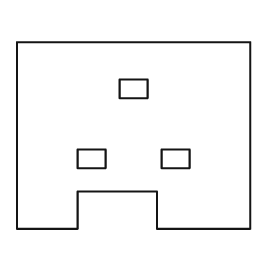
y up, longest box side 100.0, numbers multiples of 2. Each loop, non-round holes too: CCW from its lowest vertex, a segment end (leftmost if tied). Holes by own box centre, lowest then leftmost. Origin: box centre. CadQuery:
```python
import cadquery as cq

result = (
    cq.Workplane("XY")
    .moveTo(-50.0, -40.0)
    .lineTo(-24.0, -40.0)
    .lineTo(-24.0, -24.0)
    .lineTo(10.0, -24.0)
    .lineTo(10.0, -40.0)
    .lineTo(50.0, -40.0)
    .lineTo(50.0, 40.0)
    .lineTo(-50.0, 40.0)
    .close()
    .moveTo(-24.0, -14.0)
    .lineTo(-12.0, -14.0)
    .lineTo(-12.0, -6.0)
    .lineTo(-24.0, -6.0)
    .close()
    .moveTo(12.0, -14.0)
    .lineTo(24.0, -14.0)
    .lineTo(24.0, -6.0)
    .lineTo(12.0, -6.0)
    .close()
    .moveTo(-6.0, 16.0)
    .lineTo(6.0, 16.0)
    .lineTo(6.0, 24.0)
    .lineTo(-6.0, 24.0)
    .close()
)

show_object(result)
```